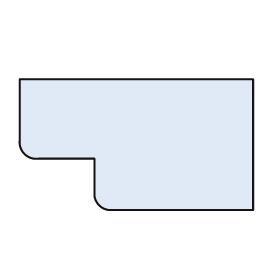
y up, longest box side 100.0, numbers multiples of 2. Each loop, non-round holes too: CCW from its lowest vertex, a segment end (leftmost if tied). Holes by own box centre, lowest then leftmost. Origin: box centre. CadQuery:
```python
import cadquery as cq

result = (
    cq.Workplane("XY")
    .moveTo(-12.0, -28.0)
    .lineTo(50.0, -28.0)
    .lineTo(50.0, 28.0)
    .lineTo(-50.0, 28.0)
    .lineTo(-50.0, 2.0)
    .threePointArc((-48.0, -4.0), (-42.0, -6.0))
    .lineTo(-18.0, -6.0)
    .lineTo(-18.0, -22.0)
    .threePointArc((-16.0, -26.0), (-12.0, -28.0))
    .close()
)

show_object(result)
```